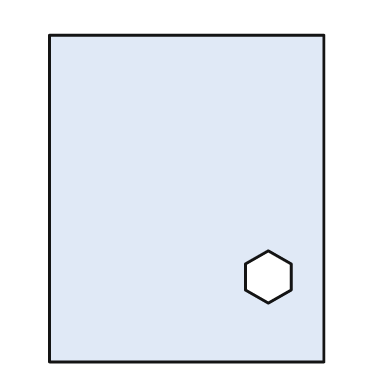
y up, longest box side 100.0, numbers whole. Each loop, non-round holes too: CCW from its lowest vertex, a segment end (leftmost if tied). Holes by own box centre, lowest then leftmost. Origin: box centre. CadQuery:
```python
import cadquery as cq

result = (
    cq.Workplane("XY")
    .moveTo(-42.0, -50.0)
    .lineTo(42.0, -50.0)
    .lineTo(42.0, 50.0)
    .lineTo(-42.0, 50.0)
    .close()
    .moveTo(25.0, -32.0)
    .lineTo(32.0, -28.0)
    .lineTo(32.0, -20.0)
    .lineTo(25.0, -16.0)
    .lineTo(18.0, -20.0)
    .lineTo(18.0, -28.0)
    .close()
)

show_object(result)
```